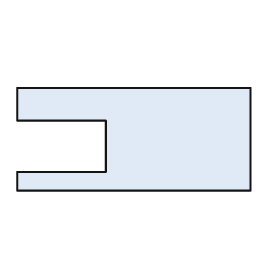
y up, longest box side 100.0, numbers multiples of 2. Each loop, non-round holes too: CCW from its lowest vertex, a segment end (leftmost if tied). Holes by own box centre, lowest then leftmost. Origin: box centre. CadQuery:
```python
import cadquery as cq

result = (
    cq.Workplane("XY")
    .moveTo(-50.0, -22.0)
    .lineTo(50.0, -22.0)
    .lineTo(50.0, 22.0)
    .lineTo(-50.0, 22.0)
    .lineTo(-50.0, 8.0)
    .lineTo(-12.0, 8.0)
    .lineTo(-12.0, -14.0)
    .lineTo(-50.0, -14.0)
    .close()
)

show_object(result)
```